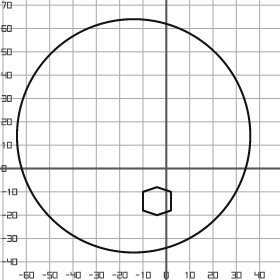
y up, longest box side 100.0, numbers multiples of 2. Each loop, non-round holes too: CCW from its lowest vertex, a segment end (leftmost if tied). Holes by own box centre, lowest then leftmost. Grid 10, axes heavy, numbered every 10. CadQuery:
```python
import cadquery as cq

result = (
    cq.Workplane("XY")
    .moveTo(-14.0, 14.0)
    .circle(50.0)
    .moveTo(-4.0, -20.0)
    .lineTo(2.0, -18.0)
    .lineTo(2.0, -10.0)
    .lineTo(-4.0, -8.0)
    .lineTo(-10.0, -10.0)
    .lineTo(-10.0, -18.0)
    .close()
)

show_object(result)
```